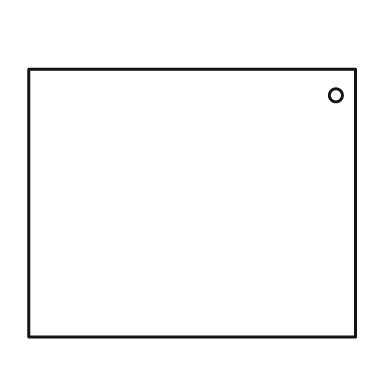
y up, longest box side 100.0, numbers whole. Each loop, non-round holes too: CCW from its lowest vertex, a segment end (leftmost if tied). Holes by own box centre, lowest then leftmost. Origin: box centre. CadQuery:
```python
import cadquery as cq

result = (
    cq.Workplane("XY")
    .moveTo(-50.0, -41.0)
    .lineTo(50.0, -41.0)
    .lineTo(50.0, 41.0)
    .lineTo(-50.0, 41.0)
    .close()
    .moveTo(44.0, 33.0)
    .circle(2.0)
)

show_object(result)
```